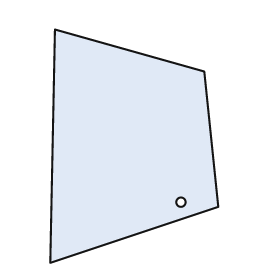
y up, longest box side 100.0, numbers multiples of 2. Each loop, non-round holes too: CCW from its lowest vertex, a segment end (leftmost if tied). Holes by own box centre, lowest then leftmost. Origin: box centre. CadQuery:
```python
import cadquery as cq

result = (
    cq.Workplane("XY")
    .moveTo(-36.0, -50.0)
    .lineTo(36.0, -26.0)
    .lineTo(30.0, 32.0)
    .lineTo(-34.0, 50.0)
    .close()
    .moveTo(20.0, -24.0)
    .circle(2.0)
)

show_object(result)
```